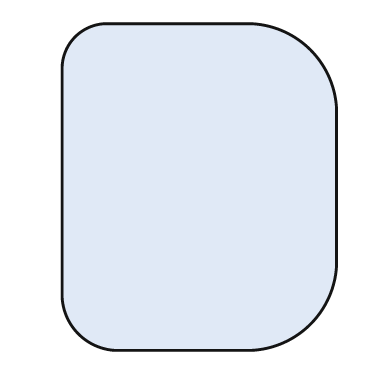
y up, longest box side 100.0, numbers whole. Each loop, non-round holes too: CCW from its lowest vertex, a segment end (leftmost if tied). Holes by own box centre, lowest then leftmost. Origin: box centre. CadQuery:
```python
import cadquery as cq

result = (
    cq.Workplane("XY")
    .moveTo(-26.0, -50.0)
    .lineTo(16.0, -50.0)
    .threePointArc((34.0, -42.0), (42.0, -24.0))
    .lineTo(42.0, 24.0)
    .threePointArc((34.0, 42.0), (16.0, 50.0))
    .lineTo(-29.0, 50.0)
    .threePointArc((-38.0, 46.0), (-42.0, 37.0))
    .lineTo(-42.0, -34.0)
    .threePointArc((-37.0, -45.0), (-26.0, -50.0))
    .close()
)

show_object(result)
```